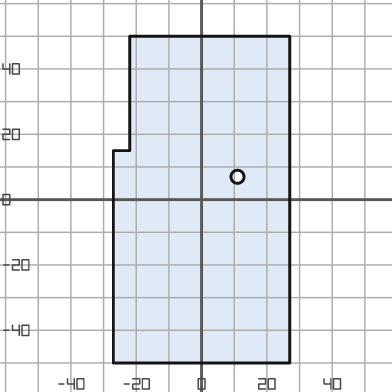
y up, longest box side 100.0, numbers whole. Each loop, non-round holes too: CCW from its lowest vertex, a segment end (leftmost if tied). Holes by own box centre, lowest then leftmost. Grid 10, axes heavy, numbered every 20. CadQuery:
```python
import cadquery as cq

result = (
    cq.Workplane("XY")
    .moveTo(-27.0, -50.0)
    .lineTo(27.0, -50.0)
    .lineTo(27.0, 50.0)
    .lineTo(-22.0, 50.0)
    .lineTo(-22.0, 15.0)
    .lineTo(-27.0, 15.0)
    .close()
    .moveTo(11.0, 7.0)
    .circle(2.0)
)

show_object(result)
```